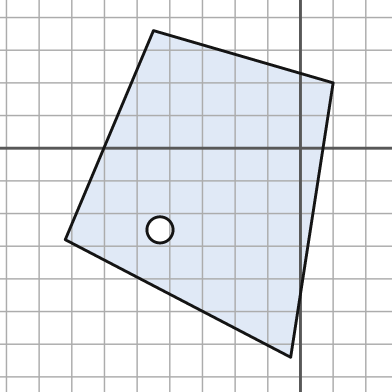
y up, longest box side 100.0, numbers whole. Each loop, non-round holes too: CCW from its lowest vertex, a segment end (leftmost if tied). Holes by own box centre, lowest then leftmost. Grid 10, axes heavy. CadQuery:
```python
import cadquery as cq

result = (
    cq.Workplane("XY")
    .moveTo(-3.0, -64.0)
    .lineTo(10.0, 20.0)
    .lineTo(-45.0, 36.0)
    .lineTo(-72.0, -28.0)
    .close()
    .moveTo(-43.0, -25.0)
    .circle(4.0)
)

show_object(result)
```